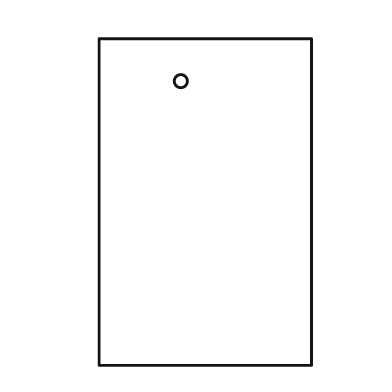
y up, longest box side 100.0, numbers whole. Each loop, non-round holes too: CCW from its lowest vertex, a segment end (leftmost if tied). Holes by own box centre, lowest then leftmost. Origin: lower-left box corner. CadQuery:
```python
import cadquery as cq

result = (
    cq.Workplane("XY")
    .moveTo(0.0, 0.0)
    .lineTo(65.0, 0.0)
    .lineTo(65.0, 100.0)
    .lineTo(0.0, 100.0)
    .close()
    .moveTo(25.0, 87.0)
    .circle(2.0)
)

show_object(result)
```